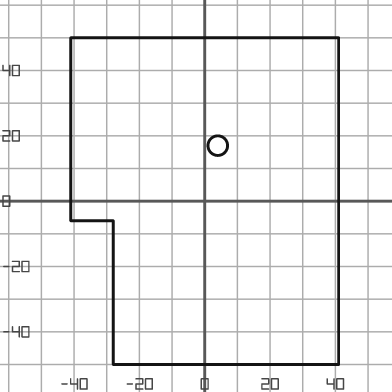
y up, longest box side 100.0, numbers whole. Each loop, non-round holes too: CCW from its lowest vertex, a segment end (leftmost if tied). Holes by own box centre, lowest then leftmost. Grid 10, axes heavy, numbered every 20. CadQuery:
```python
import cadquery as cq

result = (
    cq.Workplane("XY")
    .moveTo(-28.0, -50.0)
    .lineTo(41.0, -50.0)
    .lineTo(41.0, 50.0)
    .lineTo(-41.0, 50.0)
    .lineTo(-41.0, -6.0)
    .lineTo(-28.0, -6.0)
    .close()
    .moveTo(4.0, 17.0)
    .circle(3.0)
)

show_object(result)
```